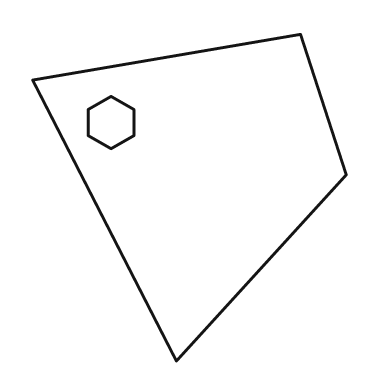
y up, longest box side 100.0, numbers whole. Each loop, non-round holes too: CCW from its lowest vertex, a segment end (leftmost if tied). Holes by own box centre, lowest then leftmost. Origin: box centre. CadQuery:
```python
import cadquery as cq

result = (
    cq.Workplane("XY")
    .moveTo(-4.0, -50.0)
    .lineTo(48.0, 7.0)
    .lineTo(34.0, 50.0)
    .lineTo(-48.0, 36.0)
    .close()
    .moveTo(-24.0, 15.0)
    .lineTo(-17.0, 19.0)
    .lineTo(-17.0, 27.0)
    .lineTo(-24.0, 31.0)
    .lineTo(-31.0, 27.0)
    .lineTo(-31.0, 19.0)
    .close()
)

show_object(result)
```